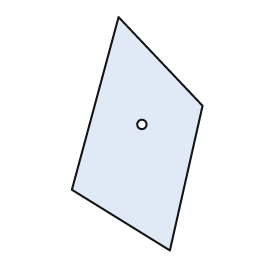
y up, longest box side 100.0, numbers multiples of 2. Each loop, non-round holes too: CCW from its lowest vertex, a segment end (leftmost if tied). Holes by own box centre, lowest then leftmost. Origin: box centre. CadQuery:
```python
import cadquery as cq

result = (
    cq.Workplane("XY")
    .moveTo(14.0, -50.0)
    .lineTo(28.0, 12.0)
    .lineTo(-8.0, 50.0)
    .lineTo(-28.0, -24.0)
    .close()
    .moveTo(2.0, 4.0)
    .circle(2.0)
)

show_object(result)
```